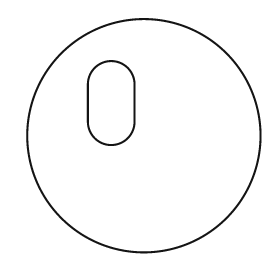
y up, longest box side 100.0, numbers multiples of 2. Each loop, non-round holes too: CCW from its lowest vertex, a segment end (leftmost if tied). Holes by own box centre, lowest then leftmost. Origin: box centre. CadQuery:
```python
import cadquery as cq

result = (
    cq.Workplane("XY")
    .moveTo(0.0, 0.0)
    .circle(50.0)
    .moveTo(-24.0, 6.0)
    .threePointArc((-14.0, -4.0), (-4.0, 6.0))
    .lineTo(-4.0, 22.0)
    .threePointArc((-14.0, 32.0), (-24.0, 22.0))
    .close()
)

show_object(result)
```